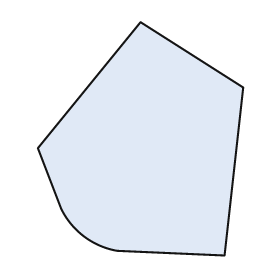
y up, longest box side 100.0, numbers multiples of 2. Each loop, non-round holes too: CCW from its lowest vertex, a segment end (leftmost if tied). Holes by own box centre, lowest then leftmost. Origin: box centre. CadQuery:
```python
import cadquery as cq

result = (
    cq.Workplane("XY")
    .moveTo(36.0, -50.0)
    .lineTo(44.0, 22.0)
    .lineTo(0.0, 50.0)
    .lineTo(-44.0, -4.0)
    .lineTo(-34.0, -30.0)
    .threePointArc((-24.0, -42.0), (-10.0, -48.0))
    .close()
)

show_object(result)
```